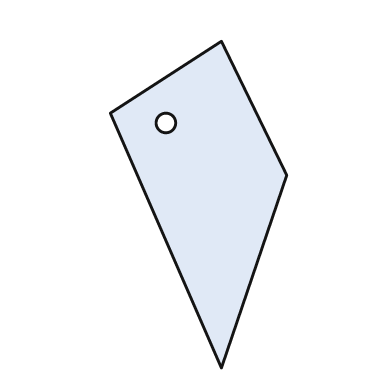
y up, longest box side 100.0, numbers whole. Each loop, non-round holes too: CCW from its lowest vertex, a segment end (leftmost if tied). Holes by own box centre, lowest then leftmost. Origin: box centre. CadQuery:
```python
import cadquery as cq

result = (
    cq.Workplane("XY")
    .moveTo(7.0, -50.0)
    .lineTo(27.0, 9.0)
    .lineTo(7.0, 50.0)
    .lineTo(-27.0, 28.0)
    .close()
    .moveTo(-10.0, 25.0)
    .circle(3.0)
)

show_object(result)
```